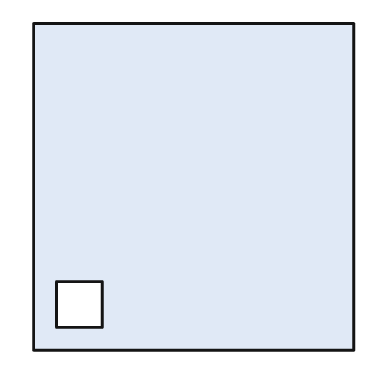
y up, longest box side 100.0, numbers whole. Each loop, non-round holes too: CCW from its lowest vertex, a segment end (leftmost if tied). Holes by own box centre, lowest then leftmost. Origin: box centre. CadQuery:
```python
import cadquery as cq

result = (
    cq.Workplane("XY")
    .moveTo(-49.0, -50.0)
    .lineTo(49.0, -50.0)
    .lineTo(49.0, 50.0)
    .lineTo(-49.0, 50.0)
    .close()
    .moveTo(-42.0, -43.0)
    .lineTo(-28.0, -43.0)
    .lineTo(-28.0, -29.0)
    .lineTo(-42.0, -29.0)
    .close()
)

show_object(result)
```